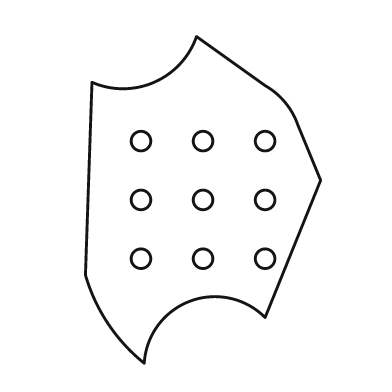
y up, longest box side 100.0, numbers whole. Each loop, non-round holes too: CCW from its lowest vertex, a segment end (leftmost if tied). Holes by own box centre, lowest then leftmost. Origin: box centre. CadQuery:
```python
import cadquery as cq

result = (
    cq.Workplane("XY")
    .moveTo(-18.0, -50.0)
    .threePointArc((-4.0, -31.0), (19.0, -36.0))
    .lineTo(36.0, 6.0)
    .lineTo(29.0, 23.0)
    .threePointArc((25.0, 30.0), (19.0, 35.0))
    .lineTo(-2.0, 50.0)
    .threePointArc((-15.0, 36.0), (-34.0, 36.0))
    .lineTo(-36.0, -23.0)
    .threePointArc((-29.0, -38.0), (-18.0, -50.0))
    .close()
    .moveTo(-19.0, -18.0)
    .circle(3.0)
    .moveTo(0.0, -18.0)
    .circle(3.0)
    .moveTo(19.0, -18.0)
    .circle(3.0)
    .moveTo(-19.0, 0.0)
    .circle(3.0)
    .moveTo(0.0, 0.0)
    .circle(3.0)
    .moveTo(19.0, 0.0)
    .circle(3.0)
    .moveTo(-19.0, 18.0)
    .circle(3.0)
    .moveTo(0.0, 18.0)
    .circle(3.0)
    .moveTo(19.0, 18.0)
    .circle(3.0)
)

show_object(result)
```